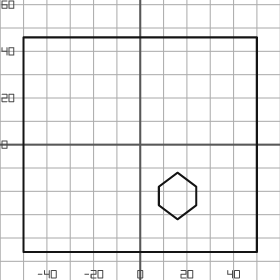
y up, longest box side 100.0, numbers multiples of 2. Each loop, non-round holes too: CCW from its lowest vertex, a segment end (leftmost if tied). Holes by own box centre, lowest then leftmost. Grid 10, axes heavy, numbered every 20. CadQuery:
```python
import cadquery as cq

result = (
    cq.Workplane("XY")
    .moveTo(-50.0, -46.0)
    .lineTo(50.0, -46.0)
    .lineTo(50.0, 46.0)
    .lineTo(-50.0, 46.0)
    .close()
    .moveTo(16.0, -32.0)
    .lineTo(24.0, -26.0)
    .lineTo(24.0, -18.0)
    .lineTo(16.0, -12.0)
    .lineTo(8.0, -18.0)
    .lineTo(8.0, -26.0)
    .close()
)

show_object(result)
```